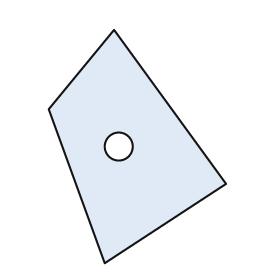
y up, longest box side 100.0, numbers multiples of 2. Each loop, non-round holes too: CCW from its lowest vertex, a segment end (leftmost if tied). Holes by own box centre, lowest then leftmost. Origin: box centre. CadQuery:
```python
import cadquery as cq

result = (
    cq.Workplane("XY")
    .moveTo(-14.0, -50.0)
    .lineTo(38.0, -16.0)
    .lineTo(-10.0, 50.0)
    .lineTo(-38.0, 16.0)
    .close()
    .moveTo(-8.0, 0.0)
    .circle(6.0)
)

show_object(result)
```